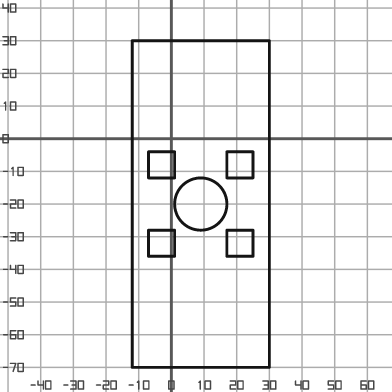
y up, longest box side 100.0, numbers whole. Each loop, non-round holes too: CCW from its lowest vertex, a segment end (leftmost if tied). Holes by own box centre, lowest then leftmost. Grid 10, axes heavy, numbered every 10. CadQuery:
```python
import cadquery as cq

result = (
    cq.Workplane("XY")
    .moveTo(-12.0, -70.0)
    .lineTo(30.0, -70.0)
    .lineTo(30.0, 30.0)
    .lineTo(-12.0, 30.0)
    .close()
    .moveTo(-7.0, -36.0)
    .lineTo(1.0, -36.0)
    .lineTo(1.0, -28.0)
    .lineTo(-7.0, -28.0)
    .close()
    .moveTo(17.0, -36.0)
    .lineTo(25.0, -36.0)
    .lineTo(25.0, -28.0)
    .lineTo(17.0, -28.0)
    .close()
    .moveTo(9.0, -20.0)
    .circle(8.0)
    .moveTo(-7.0, -12.0)
    .lineTo(1.0, -12.0)
    .lineTo(1.0, -4.0)
    .lineTo(-7.0, -4.0)
    .close()
    .moveTo(17.0, -12.0)
    .lineTo(25.0, -12.0)
    .lineTo(25.0, -4.0)
    .lineTo(17.0, -4.0)
    .close()
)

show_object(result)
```